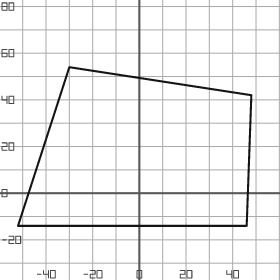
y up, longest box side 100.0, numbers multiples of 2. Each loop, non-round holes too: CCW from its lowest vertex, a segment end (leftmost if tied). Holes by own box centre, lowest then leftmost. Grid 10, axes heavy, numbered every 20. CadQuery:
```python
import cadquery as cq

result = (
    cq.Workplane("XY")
    .moveTo(-52.0, -14.0)
    .lineTo(46.0, -14.0)
    .lineTo(48.0, 42.0)
    .lineTo(-30.0, 54.0)
    .close()
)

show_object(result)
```